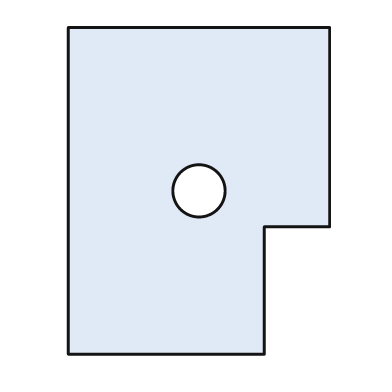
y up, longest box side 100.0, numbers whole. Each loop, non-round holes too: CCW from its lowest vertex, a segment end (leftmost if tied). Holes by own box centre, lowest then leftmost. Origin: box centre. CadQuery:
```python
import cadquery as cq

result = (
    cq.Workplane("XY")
    .moveTo(-40.0, -50.0)
    .lineTo(20.0, -50.0)
    .lineTo(20.0, -11.0)
    .lineTo(40.0, -11.0)
    .lineTo(40.0, 50.0)
    .lineTo(-40.0, 50.0)
    .close()
    .moveTo(0.0, 0.0)
    .circle(8.0)
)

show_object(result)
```